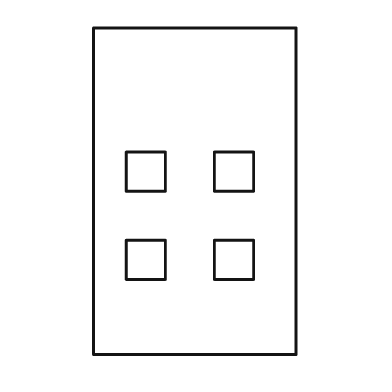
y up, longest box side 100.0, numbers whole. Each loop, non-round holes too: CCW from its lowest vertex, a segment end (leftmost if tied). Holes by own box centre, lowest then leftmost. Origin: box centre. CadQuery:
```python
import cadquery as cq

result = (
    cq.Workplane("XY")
    .moveTo(-31.0, -50.0)
    .lineTo(31.0, -50.0)
    .lineTo(31.0, 50.0)
    .lineTo(-31.0, 50.0)
    .close()
    .moveTo(-21.0, -27.0)
    .lineTo(-9.0, -27.0)
    .lineTo(-9.0, -15.0)
    .lineTo(-21.0, -15.0)
    .close()
    .moveTo(6.0, -27.0)
    .lineTo(18.0, -27.0)
    .lineTo(18.0, -15.0)
    .lineTo(6.0, -15.0)
    .close()
    .moveTo(-21.0, 0.0)
    .lineTo(-9.0, 0.0)
    .lineTo(-9.0, 12.0)
    .lineTo(-21.0, 12.0)
    .close()
    .moveTo(6.0, 0.0)
    .lineTo(18.0, 0.0)
    .lineTo(18.0, 12.0)
    .lineTo(6.0, 12.0)
    .close()
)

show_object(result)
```